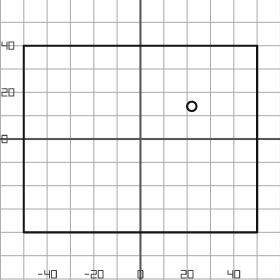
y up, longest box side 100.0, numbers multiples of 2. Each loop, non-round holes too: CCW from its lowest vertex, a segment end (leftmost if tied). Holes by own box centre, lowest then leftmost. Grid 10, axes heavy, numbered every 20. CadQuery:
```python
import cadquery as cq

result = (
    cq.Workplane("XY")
    .moveTo(-50.0, -40.0)
    .lineTo(50.0, -40.0)
    .lineTo(50.0, 40.0)
    .lineTo(-50.0, 40.0)
    .close()
    .moveTo(22.0, 14.0)
    .circle(2.0)
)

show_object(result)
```